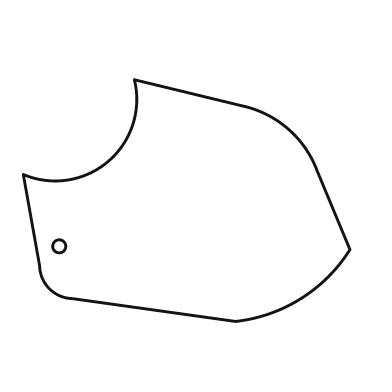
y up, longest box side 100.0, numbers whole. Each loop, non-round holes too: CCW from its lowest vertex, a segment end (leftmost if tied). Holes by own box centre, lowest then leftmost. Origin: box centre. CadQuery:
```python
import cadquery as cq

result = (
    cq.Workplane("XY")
    .moveTo(15.0, -37.0)
    .threePointArc((35.0, -30.0), (50.0, -15.0))
    .lineTo(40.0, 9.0)
    .threePointArc((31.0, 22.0), (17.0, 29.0))
    .lineTo(-16.0, 37.0)
    .threePointArc((-24.0, 12.0), (-50.0, 8.0))
    .lineTo(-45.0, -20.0)
    .threePointArc((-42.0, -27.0), (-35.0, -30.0))
    .close()
    .moveTo(-39.0, -14.0)
    .circle(2.0)
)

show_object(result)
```